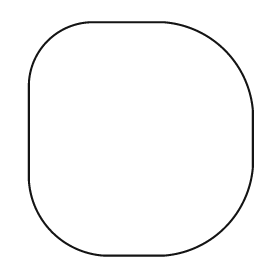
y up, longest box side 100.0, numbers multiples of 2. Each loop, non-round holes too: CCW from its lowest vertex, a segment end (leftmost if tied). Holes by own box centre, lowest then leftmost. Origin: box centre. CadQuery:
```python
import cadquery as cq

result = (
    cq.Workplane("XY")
    .moveTo(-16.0, -50.0)
    .lineTo(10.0, -50.0)
    .threePointArc((36.0, -38.0), (48.0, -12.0))
    .lineTo(48.0, 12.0)
    .threePointArc((36.0, 38.0), (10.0, 50.0))
    .lineTo(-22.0, 50.0)
    .threePointArc((-40.0, 42.0), (-48.0, 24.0))
    .lineTo(-48.0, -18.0)
    .threePointArc((-38.0, -40.0), (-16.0, -50.0))
    .close()
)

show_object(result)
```